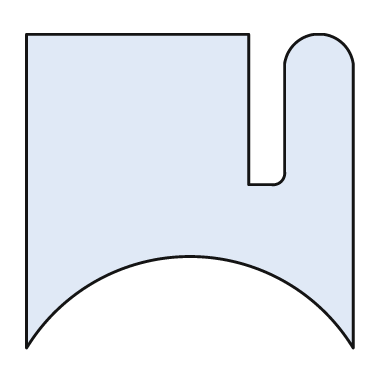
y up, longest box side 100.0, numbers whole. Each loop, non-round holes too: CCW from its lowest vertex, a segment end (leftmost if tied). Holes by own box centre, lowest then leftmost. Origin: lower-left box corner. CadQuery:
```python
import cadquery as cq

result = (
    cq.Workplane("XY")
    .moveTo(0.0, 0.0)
    .threePointArc((50.0, 28.0), (100.0, 0.0))
    .lineTo(100.0, 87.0)
    .threePointArc((97.0, 93.0), (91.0, 96.0))
    .lineTo(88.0, 96.0)
    .threePointArc((82.0, 93.0), (79.0, 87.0))
    .lineTo(79.0, 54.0)
    .threePointArc((78.0, 51.0), (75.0, 50.0))
    .lineTo(68.0, 50.0)
    .lineTo(68.0, 96.0)
    .lineTo(0.0, 96.0)
    .close()
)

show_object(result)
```